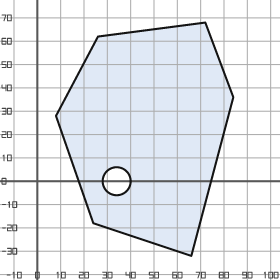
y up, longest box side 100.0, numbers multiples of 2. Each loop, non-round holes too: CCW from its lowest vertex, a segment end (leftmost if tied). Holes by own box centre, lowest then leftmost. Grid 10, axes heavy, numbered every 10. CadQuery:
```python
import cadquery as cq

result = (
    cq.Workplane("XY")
    .moveTo(66.0, -32.0)
    .lineTo(84.0, 36.0)
    .lineTo(72.0, 68.0)
    .lineTo(26.0, 62.0)
    .lineTo(8.0, 28.0)
    .lineTo(24.0, -18.0)
    .close()
    .moveTo(34.0, 0.0)
    .circle(6.0)
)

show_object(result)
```